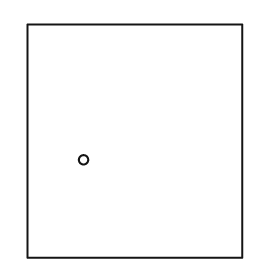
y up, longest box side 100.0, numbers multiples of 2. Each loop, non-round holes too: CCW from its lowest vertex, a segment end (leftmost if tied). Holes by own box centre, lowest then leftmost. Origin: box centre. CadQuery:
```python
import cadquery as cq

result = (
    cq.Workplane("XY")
    .moveTo(-46.0, -50.0)
    .lineTo(46.0, -50.0)
    .lineTo(46.0, 50.0)
    .lineTo(-46.0, 50.0)
    .close()
    .moveTo(-22.0, -8.0)
    .circle(2.0)
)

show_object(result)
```